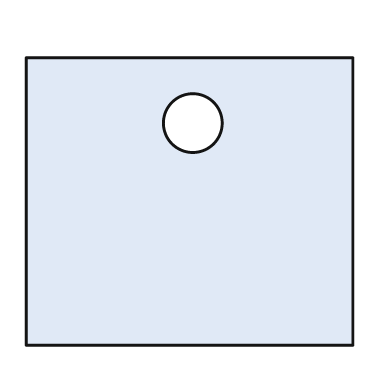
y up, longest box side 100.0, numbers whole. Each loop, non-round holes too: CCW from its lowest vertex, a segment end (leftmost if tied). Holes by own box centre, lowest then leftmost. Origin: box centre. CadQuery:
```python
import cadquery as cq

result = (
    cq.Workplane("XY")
    .moveTo(-50.0, -44.0)
    .lineTo(50.0, -44.0)
    .lineTo(50.0, 44.0)
    .lineTo(-50.0, 44.0)
    .close()
    .moveTo(1.0, 24.0)
    .circle(9.0)
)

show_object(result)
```